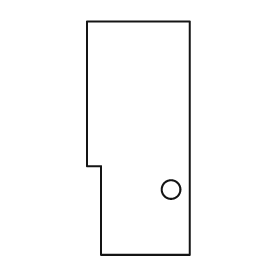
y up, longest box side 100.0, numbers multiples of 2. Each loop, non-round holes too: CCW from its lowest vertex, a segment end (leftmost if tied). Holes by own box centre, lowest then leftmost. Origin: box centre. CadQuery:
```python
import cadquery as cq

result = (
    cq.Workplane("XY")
    .moveTo(-16.0, -50.0)
    .lineTo(22.0, -50.0)
    .lineTo(22.0, 50.0)
    .lineTo(-22.0, 50.0)
    .lineTo(-22.0, -12.0)
    .lineTo(-16.0, -12.0)
    .close()
    .moveTo(14.0, -22.0)
    .circle(4.0)
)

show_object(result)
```